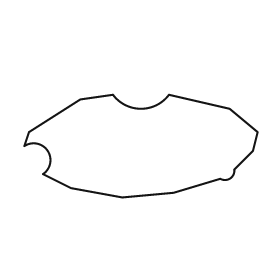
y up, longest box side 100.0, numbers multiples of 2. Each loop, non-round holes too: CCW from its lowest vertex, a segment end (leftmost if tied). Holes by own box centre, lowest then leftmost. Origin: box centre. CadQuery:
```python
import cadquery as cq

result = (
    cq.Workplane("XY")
    .moveTo(-8.0, -22.0)
    .lineTo(14.0, -20.0)
    .lineTo(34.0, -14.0)
    .threePointArc((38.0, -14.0), (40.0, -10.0))
    .lineTo(48.0, -2.0)
    .lineTo(50.0, 6.0)
    .lineTo(38.0, 16.0)
    .lineTo(12.0, 22.0)
    .threePointArc((0.0, 16.0), (-12.0, 22.0))
    .lineTo(-26.0, 20.0)
    .lineTo(-48.0, 6.0)
    .lineTo(-50.0, 0.0)
    .threePointArc((-40.0, -2.0), (-42.0, -12.0))
    .lineTo(-30.0, -18.0)
    .close()
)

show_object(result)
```